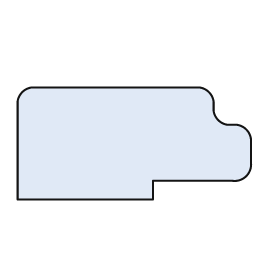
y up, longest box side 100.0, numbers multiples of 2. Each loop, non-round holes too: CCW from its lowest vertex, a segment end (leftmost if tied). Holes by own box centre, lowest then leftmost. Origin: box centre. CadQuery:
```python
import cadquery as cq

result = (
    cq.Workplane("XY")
    .moveTo(-50.0, -24.0)
    .lineTo(8.0, -24.0)
    .lineTo(8.0, -16.0)
    .lineTo(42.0, -16.0)
    .threePointArc((48.0, -14.0), (50.0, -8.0))
    .lineTo(50.0, 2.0)
    .threePointArc((48.0, 6.0), (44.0, 8.0))
    .lineTo(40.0, 8.0)
    .threePointArc((36.0, 10.0), (34.0, 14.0))
    .lineTo(34.0, 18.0)
    .threePointArc((32.0, 22.0), (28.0, 24.0))
    .lineTo(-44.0, 24.0)
    .threePointArc((-48.0, 22.0), (-50.0, 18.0))
    .close()
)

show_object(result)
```